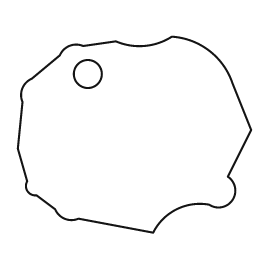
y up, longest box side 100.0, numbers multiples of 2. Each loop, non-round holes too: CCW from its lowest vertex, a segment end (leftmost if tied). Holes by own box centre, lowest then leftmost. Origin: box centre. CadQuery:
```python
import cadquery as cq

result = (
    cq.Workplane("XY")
    .moveTo(8.0, -42.0)
    .threePointArc((18.0, -32.0), (32.0, -30.0))
    .threePointArc((42.0, -28.0), (40.0, -18.0))
    .lineTo(50.0, 2.0)
    .lineTo(42.0, 22.0)
    .threePointArc((32.0, 36.0), (16.0, 42.0))
    .threePointArc((4.0, 38.0), (-8.0, 40.0))
    .lineTo(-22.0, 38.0)
    .threePointArc((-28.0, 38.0), (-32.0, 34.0))
    .lineTo(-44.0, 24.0)
    .threePointArc((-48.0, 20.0), (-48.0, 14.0))
    .lineTo(-50.0, -6.0)
    .lineTo(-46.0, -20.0)
    .threePointArc((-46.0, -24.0), (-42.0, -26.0))
    .lineTo(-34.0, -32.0)
    .threePointArc((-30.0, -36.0), (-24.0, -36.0))
    .close()
    .moveTo(-20.0, 26.0)
    .circle(6.0)
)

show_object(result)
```